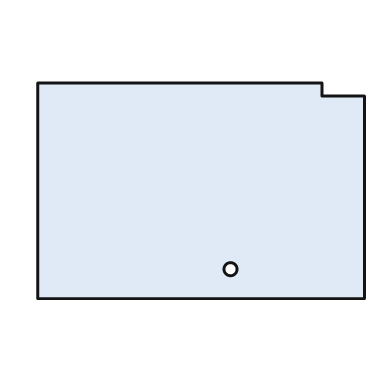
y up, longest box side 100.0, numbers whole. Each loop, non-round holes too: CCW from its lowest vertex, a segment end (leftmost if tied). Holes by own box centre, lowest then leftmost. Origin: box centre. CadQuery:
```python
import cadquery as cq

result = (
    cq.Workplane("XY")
    .moveTo(-50.0, -33.0)
    .lineTo(50.0, -33.0)
    .lineTo(50.0, 29.0)
    .lineTo(37.0, 29.0)
    .lineTo(37.0, 33.0)
    .lineTo(-50.0, 33.0)
    .close()
    .moveTo(9.0, -24.0)
    .circle(2.0)
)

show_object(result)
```